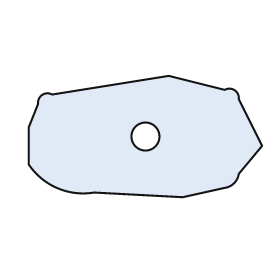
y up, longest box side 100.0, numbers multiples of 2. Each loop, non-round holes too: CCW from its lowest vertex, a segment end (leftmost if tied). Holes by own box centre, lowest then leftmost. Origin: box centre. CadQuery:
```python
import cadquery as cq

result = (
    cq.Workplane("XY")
    .moveTo(16.0, -26.0)
    .lineTo(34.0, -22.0)
    .threePointArc((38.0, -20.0), (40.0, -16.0))
    .lineTo(50.0, -4.0)
    .lineTo(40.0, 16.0)
    .threePointArc((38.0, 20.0), (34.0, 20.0))
    .lineTo(10.0, 26.0)
    .lineTo(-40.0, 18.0)
    .threePointArc((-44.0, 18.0), (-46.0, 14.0))
    .lineTo(-50.0, 4.0)
    .lineTo(-50.0, -12.0)
    .threePointArc((-38.0, -22.0), (-22.0, -24.0))
    .close()
    .moveTo(0.0, 0.0)
    .circle(6.0)
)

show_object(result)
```